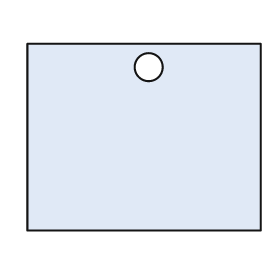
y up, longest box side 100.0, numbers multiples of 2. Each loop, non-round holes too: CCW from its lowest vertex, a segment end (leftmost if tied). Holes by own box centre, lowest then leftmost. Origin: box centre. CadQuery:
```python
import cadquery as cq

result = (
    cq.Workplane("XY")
    .moveTo(-50.0, -40.0)
    .lineTo(50.0, -40.0)
    .lineTo(50.0, 40.0)
    .lineTo(-50.0, 40.0)
    .close()
    .moveTo(2.0, 30.0)
    .circle(6.0)
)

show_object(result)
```